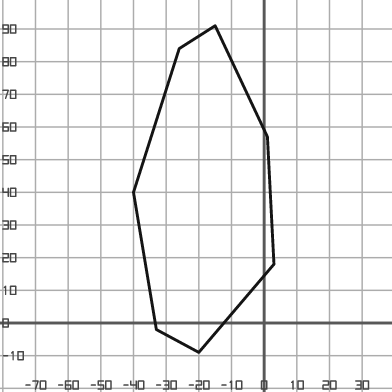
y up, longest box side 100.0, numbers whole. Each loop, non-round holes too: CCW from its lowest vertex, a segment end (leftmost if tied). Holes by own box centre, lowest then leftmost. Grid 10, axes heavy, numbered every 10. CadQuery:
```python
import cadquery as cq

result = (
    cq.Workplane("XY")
    .moveTo(-20.0, -9.0)
    .lineTo(3.0, 18.0)
    .lineTo(1.0, 57.0)
    .lineTo(-15.0, 91.0)
    .lineTo(-26.0, 84.0)
    .lineTo(-40.0, 40.0)
    .lineTo(-33.0, -2.0)
    .close()
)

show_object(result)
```